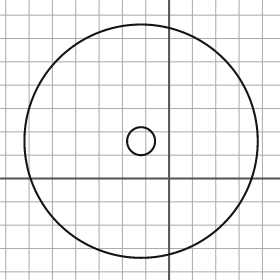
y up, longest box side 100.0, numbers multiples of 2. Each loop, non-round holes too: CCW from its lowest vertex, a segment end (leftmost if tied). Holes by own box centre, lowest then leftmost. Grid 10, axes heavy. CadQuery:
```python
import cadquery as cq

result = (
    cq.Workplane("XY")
    .moveTo(-12.0, 16.0)
    .circle(50.0)
    .moveTo(-12.0, 16.0)
    .circle(6.0)
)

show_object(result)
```